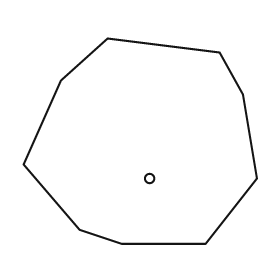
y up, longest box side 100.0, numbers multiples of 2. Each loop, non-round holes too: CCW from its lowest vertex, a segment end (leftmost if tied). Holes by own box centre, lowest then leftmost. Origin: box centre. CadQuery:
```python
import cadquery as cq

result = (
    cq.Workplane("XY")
    .moveTo(-8.0, -44.0)
    .lineTo(28.0, -44.0)
    .lineTo(50.0, -16.0)
    .lineTo(44.0, 20.0)
    .lineTo(34.0, 38.0)
    .lineTo(-14.0, 44.0)
    .lineTo(-34.0, 26.0)
    .lineTo(-50.0, -10.0)
    .lineTo(-26.0, -38.0)
    .close()
    .moveTo(4.0, -16.0)
    .circle(2.0)
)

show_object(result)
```